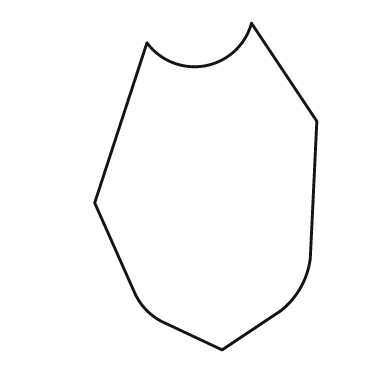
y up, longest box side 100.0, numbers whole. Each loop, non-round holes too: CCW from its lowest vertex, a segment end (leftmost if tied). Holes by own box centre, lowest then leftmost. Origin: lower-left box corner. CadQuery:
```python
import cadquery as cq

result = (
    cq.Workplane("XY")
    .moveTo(39.0, 0.0)
    .lineTo(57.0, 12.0)
    .threePointArc((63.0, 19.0), (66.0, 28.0))
    .lineTo(68.0, 70.0)
    .lineTo(48.0, 100.0)
    .threePointArc((34.0, 87.0), (16.0, 94.0))
    .lineTo(0.0, 45.0)
    .lineTo(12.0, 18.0)
    .threePointArc((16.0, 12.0), (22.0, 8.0))
    .close()
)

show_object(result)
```